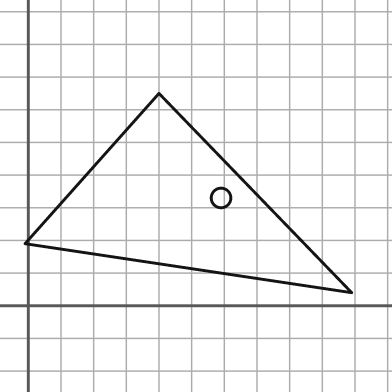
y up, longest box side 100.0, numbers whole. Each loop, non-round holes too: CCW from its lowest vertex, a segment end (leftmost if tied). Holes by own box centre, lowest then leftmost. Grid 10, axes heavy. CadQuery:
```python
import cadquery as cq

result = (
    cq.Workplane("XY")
    .moveTo(99.0, 4.0)
    .lineTo(40.0, 65.0)
    .lineTo(-1.0, 19.0)
    .close()
    .moveTo(59.0, 33.0)
    .circle(3.0)
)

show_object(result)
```